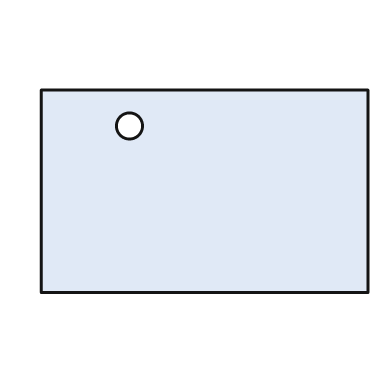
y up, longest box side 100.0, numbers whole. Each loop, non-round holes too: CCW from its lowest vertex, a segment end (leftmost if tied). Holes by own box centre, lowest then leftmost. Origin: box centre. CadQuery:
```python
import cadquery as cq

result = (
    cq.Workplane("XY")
    .moveTo(-50.0, -31.0)
    .lineTo(50.0, -31.0)
    .lineTo(50.0, 31.0)
    .lineTo(-50.0, 31.0)
    .close()
    .moveTo(-23.0, 20.0)
    .circle(4.0)
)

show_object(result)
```